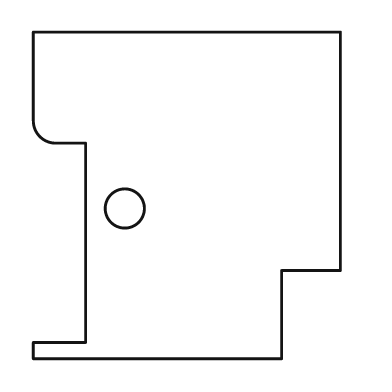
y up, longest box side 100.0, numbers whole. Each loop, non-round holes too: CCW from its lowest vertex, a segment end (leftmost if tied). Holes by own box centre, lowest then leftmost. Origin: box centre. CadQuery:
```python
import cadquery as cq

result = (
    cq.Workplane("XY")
    .moveTo(-47.0, -50.0)
    .lineTo(29.0, -50.0)
    .lineTo(29.0, -23.0)
    .lineTo(47.0, -23.0)
    .lineTo(47.0, 50.0)
    .lineTo(-47.0, 50.0)
    .lineTo(-47.0, 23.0)
    .threePointArc((-45.0, 18.0), (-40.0, 16.0))
    .lineTo(-31.0, 16.0)
    .lineTo(-31.0, -45.0)
    .lineTo(-47.0, -45.0)
    .close()
    .moveTo(-19.0, -4.0)
    .circle(6.0)
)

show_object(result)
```